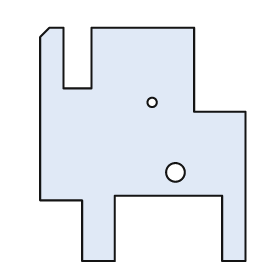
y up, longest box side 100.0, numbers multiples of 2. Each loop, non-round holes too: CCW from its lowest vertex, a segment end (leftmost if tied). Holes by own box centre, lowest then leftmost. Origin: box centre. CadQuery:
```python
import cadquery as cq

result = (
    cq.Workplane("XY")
    .moveTo(-26.0, -50.0)
    .lineTo(-12.0, -50.0)
    .lineTo(-12.0, -22.0)
    .lineTo(34.0, -22.0)
    .lineTo(34.0, -50.0)
    .lineTo(44.0, -50.0)
    .lineTo(44.0, 14.0)
    .lineTo(22.0, 14.0)
    .lineTo(22.0, 50.0)
    .lineTo(-22.0, 50.0)
    .lineTo(-22.0, 24.0)
    .lineTo(-34.0, 24.0)
    .lineTo(-34.0, 50.0)
    .lineTo(-40.0, 50.0)
    .lineTo(-44.0, 46.0)
    .lineTo(-44.0, -24.0)
    .lineTo(-26.0, -24.0)
    .close()
    .moveTo(14.0, -12.0)
    .circle(4.0)
    .moveTo(4.0, 18.0)
    .circle(2.0)
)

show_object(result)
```